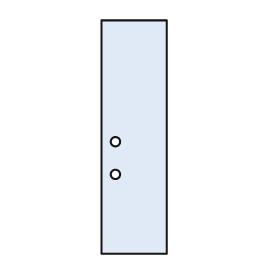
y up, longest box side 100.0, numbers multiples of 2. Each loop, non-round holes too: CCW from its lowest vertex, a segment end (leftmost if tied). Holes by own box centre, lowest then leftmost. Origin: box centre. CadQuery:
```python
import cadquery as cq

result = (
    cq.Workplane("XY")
    .moveTo(-14.0, -50.0)
    .lineTo(14.0, -50.0)
    .lineTo(14.0, 50.0)
    .lineTo(-14.0, 50.0)
    .close()
    .moveTo(-8.0, -16.0)
    .circle(2.0)
    .moveTo(-8.0, -2.0)
    .circle(2.0)
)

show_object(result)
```